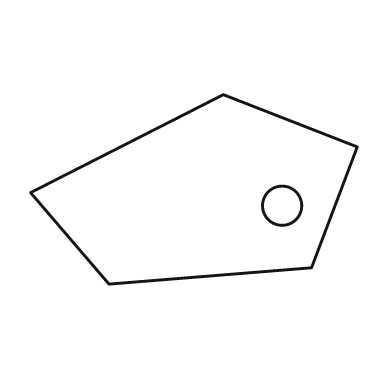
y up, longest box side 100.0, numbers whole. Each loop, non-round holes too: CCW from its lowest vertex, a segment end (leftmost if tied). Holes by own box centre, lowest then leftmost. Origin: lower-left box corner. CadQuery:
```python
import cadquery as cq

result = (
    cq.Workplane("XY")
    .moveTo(24.0, 0.0)
    .lineTo(86.0, 5.0)
    .lineTo(100.0, 42.0)
    .lineTo(59.0, 58.0)
    .lineTo(0.0, 28.0)
    .close()
    .moveTo(77.0, 24.0)
    .circle(6.0)
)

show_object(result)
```